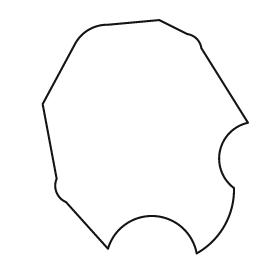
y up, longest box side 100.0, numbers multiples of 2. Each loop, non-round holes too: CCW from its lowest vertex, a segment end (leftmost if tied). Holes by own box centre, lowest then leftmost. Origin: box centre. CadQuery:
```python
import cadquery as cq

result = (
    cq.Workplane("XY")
    .moveTo(22.0, -50.0)
    .threePointArc((34.0, -38.0), (38.0, -22.0))
    .threePointArc((32.0, -6.0), (44.0, 6.0))
    .lineTo(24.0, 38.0)
    .threePointArc((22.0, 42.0), (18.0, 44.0))
    .lineTo(6.0, 50.0)
    .lineTo(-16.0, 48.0)
    .threePointArc((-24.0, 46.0), (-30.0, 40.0))
    .lineTo(-44.0, 14.0)
    .lineTo(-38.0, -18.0)
    .threePointArc((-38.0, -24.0), (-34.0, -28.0))
    .lineTo(-16.0, -48.0)
    .threePointArc((4.0, -34.0), (22.0, -50.0))
    .close()
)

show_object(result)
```